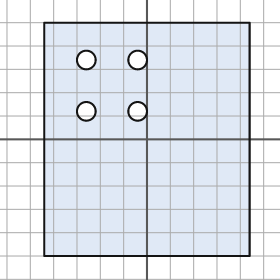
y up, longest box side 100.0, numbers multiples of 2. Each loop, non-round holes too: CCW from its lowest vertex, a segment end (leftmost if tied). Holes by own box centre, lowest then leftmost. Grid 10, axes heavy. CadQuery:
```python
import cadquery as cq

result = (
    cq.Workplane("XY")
    .moveTo(-44.0, -50.0)
    .lineTo(44.0, -50.0)
    .lineTo(44.0, 50.0)
    .lineTo(-44.0, 50.0)
    .close()
    .moveTo(-26.0, 12.0)
    .circle(4.0)
    .moveTo(-4.0, 12.0)
    .circle(4.0)
    .moveTo(-26.0, 34.0)
    .circle(4.0)
    .moveTo(-4.0, 34.0)
    .circle(4.0)
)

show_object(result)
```